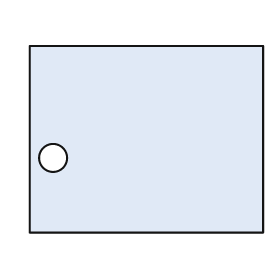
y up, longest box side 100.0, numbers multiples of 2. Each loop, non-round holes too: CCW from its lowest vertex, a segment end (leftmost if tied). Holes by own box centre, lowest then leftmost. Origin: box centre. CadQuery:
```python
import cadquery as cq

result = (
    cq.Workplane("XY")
    .moveTo(-50.0, -40.0)
    .lineTo(50.0, -40.0)
    .lineTo(50.0, 40.0)
    .lineTo(-50.0, 40.0)
    .close()
    .moveTo(-40.0, -8.0)
    .circle(6.0)
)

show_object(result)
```